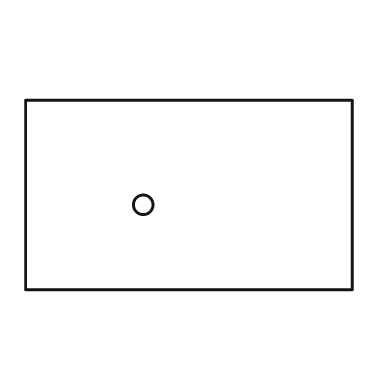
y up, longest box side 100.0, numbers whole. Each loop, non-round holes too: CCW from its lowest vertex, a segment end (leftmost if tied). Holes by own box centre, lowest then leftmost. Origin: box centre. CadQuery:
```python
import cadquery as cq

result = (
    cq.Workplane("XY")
    .moveTo(-50.0, -29.0)
    .lineTo(50.0, -29.0)
    .lineTo(50.0, 29.0)
    .lineTo(-50.0, 29.0)
    .close()
    .moveTo(-14.0, -3.0)
    .circle(3.0)
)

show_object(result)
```